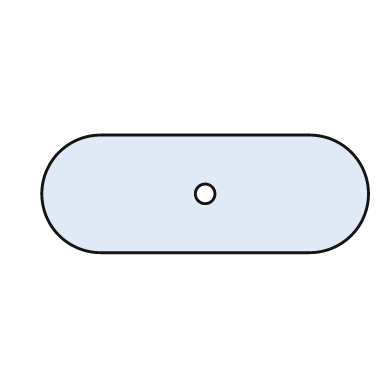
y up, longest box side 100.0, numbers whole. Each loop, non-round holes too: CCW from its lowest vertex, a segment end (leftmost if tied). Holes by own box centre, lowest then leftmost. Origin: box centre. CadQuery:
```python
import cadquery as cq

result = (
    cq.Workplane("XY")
    .moveTo(-32.0, -18.0)
    .lineTo(32.0, -18.0)
    .threePointArc((50.0, 0.0), (32.0, 18.0))
    .lineTo(-32.0, 18.0)
    .threePointArc((-50.0, 0.0), (-32.0, -18.0))
    .close()
    .moveTo(0.0, 0.0)
    .circle(3.0)
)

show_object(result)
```